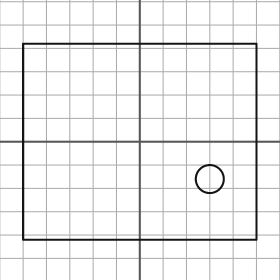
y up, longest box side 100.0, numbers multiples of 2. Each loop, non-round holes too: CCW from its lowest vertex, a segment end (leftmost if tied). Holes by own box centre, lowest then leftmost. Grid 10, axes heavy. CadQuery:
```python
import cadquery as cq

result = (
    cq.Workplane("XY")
    .moveTo(-50.0, -42.0)
    .lineTo(50.0, -42.0)
    .lineTo(50.0, 42.0)
    .lineTo(-50.0, 42.0)
    .close()
    .moveTo(30.0, -16.0)
    .circle(6.0)
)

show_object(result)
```